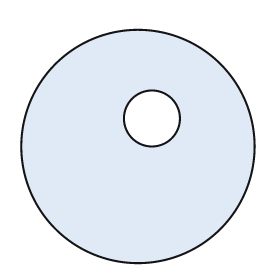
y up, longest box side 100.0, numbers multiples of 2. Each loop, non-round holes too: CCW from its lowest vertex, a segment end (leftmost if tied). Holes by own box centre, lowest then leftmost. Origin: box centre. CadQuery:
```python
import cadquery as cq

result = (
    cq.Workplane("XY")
    .moveTo(0.0, 0.0)
    .circle(50.0)
    .moveTo(6.0, 12.0)
    .circle(12.0)
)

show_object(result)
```